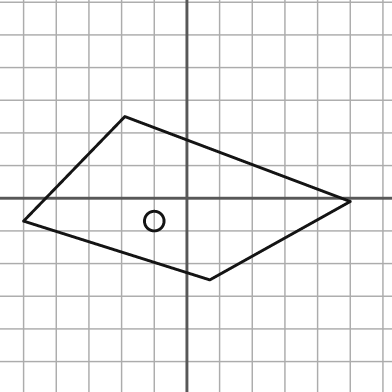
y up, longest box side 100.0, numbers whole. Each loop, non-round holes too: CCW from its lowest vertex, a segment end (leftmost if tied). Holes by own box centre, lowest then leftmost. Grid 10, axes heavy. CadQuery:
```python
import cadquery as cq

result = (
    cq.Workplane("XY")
    .moveTo(7.0, -25.0)
    .lineTo(50.0, -1.0)
    .lineTo(-19.0, 25.0)
    .lineTo(-50.0, -7.0)
    .close()
    .moveTo(-10.0, -7.0)
    .circle(3.0)
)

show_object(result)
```